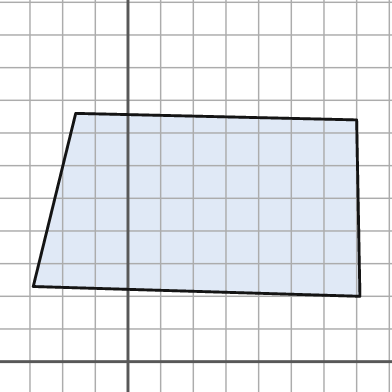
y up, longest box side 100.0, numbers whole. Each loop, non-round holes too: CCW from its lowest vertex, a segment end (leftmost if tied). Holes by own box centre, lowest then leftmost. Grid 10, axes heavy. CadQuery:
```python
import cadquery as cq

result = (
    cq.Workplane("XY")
    .moveTo(71.0, 20.0)
    .lineTo(70.0, 74.0)
    .lineTo(-16.0, 76.0)
    .lineTo(-29.0, 23.0)
    .close()
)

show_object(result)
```